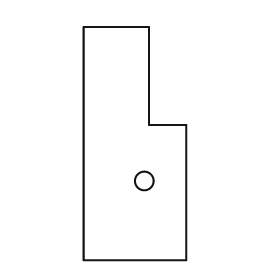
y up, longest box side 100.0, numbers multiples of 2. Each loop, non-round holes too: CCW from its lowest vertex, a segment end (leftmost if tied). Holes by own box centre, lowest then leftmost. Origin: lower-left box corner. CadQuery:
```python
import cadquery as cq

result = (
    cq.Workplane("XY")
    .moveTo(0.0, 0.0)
    .lineTo(44.0, 0.0)
    .lineTo(44.0, 58.0)
    .lineTo(28.0, 58.0)
    .lineTo(28.0, 100.0)
    .lineTo(0.0, 100.0)
    .close()
    .moveTo(26.0, 34.0)
    .circle(4.0)
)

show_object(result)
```